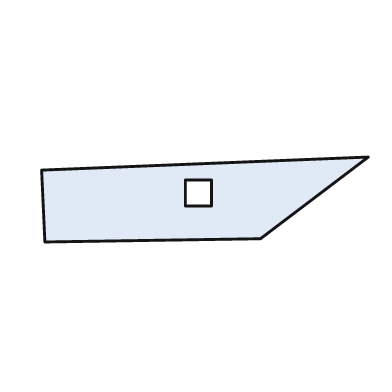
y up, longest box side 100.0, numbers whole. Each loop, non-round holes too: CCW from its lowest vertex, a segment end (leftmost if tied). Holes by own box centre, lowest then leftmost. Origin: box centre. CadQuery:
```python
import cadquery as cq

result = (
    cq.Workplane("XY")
    .moveTo(-49.0, -13.0)
    .lineTo(17.0, -12.0)
    .lineTo(50.0, 13.0)
    .lineTo(-50.0, 9.0)
    .close()
    .moveTo(-6.0, -2.0)
    .lineTo(2.0, -2.0)
    .lineTo(2.0, 6.0)
    .lineTo(-6.0, 6.0)
    .close()
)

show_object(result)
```